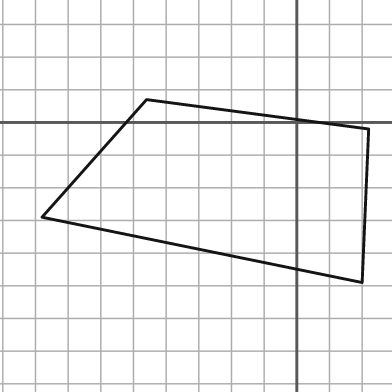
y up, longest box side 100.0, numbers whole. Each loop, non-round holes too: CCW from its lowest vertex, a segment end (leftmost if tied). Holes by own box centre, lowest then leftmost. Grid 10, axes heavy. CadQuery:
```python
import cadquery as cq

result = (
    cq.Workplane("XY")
    .moveTo(20.0, -49.0)
    .lineTo(22.0, -2.0)
    .lineTo(-46.0, 7.0)
    .lineTo(-78.0, -29.0)
    .close()
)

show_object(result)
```